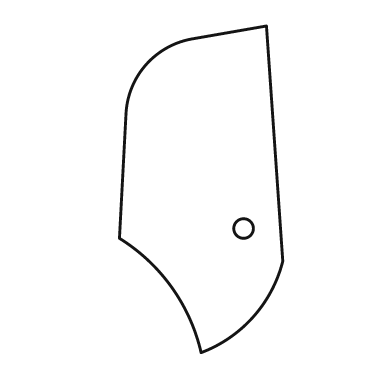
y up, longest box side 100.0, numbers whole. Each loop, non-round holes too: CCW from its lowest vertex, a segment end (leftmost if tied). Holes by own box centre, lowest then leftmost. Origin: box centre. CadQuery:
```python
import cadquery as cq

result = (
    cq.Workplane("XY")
    .moveTo(0.0, -50.0)
    .threePointArc((16.0, -39.0), (25.0, -22.0))
    .lineTo(20.0, 50.0)
    .lineTo(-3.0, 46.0)
    .threePointArc((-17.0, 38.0), (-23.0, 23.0))
    .lineTo(-25.0, -15.0)
    .threePointArc((-9.0, -30.0), (0.0, -50.0))
    .close()
    .moveTo(13.0, -12.0)
    .circle(3.0)
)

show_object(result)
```